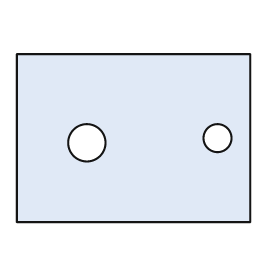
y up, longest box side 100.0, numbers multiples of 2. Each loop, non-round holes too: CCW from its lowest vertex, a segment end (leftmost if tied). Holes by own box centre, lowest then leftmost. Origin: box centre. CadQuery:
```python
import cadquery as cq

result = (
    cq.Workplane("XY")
    .moveTo(-50.0, -36.0)
    .lineTo(50.0, -36.0)
    .lineTo(50.0, 36.0)
    .lineTo(-50.0, 36.0)
    .close()
    .moveTo(-20.0, -2.0)
    .circle(8.0)
    .moveTo(36.0, 0.0)
    .circle(6.0)
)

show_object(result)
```